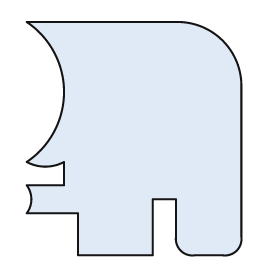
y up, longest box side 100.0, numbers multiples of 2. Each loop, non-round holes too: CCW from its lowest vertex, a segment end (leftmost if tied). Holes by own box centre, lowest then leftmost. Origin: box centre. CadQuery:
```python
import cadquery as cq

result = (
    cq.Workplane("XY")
    .moveTo(-24.0, -50.0)
    .lineTo(8.0, -50.0)
    .lineTo(8.0, -26.0)
    .lineTo(18.0, -26.0)
    .lineTo(18.0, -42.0)
    .threePointArc((20.0, -48.0), (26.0, -50.0))
    .lineTo(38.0, -50.0)
    .threePointArc((44.0, -48.0), (46.0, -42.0))
    .lineTo(46.0, 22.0)
    .threePointArc((38.0, 42.0), (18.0, 50.0))
    .lineTo(-46.0, 50.0)
    .threePointArc((-30.0, 20.0), (-46.0, -10.0))
    .threePointArc((-38.0, -12.0), (-30.0, -10.0))
    .lineTo(-30.0, -20.0)
    .lineTo(-46.0, -20.0)
    .threePointArc((-44.0, -26.0), (-46.0, -32.0))
    .lineTo(-24.0, -32.0)
    .close()
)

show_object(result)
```